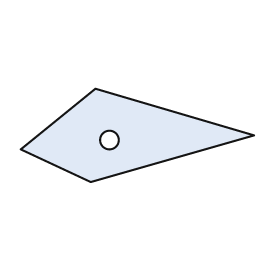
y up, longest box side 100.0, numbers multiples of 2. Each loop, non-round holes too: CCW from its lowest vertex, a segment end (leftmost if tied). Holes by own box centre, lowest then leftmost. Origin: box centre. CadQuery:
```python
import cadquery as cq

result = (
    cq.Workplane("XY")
    .moveTo(-20.0, -20.0)
    .lineTo(50.0, 0.0)
    .lineTo(-18.0, 20.0)
    .lineTo(-50.0, -6.0)
    .close()
    .moveTo(-12.0, -2.0)
    .circle(4.0)
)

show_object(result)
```